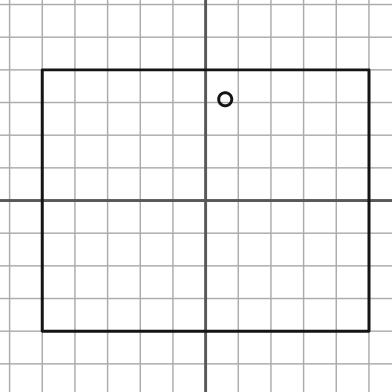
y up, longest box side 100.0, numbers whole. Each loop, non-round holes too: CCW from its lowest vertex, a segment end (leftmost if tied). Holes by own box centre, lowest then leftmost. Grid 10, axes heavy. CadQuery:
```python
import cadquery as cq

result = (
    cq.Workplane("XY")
    .moveTo(-50.0, -40.0)
    .lineTo(50.0, -40.0)
    .lineTo(50.0, 40.0)
    .lineTo(-50.0, 40.0)
    .close()
    .moveTo(6.0, 31.0)
    .circle(2.0)
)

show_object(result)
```